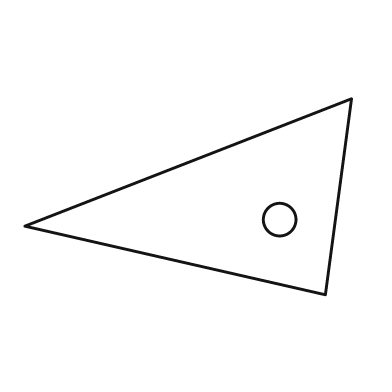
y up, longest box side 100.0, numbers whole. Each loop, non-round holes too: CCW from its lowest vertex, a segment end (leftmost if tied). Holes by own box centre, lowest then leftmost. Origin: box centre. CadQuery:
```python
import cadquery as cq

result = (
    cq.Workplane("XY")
    .moveTo(42.0, -30.0)
    .lineTo(50.0, 30.0)
    .lineTo(-50.0, -9.0)
    .close()
    .moveTo(28.0, -7.0)
    .circle(5.0)
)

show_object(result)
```